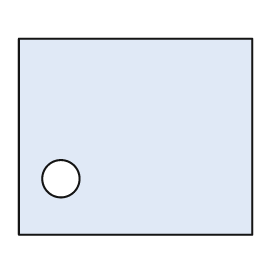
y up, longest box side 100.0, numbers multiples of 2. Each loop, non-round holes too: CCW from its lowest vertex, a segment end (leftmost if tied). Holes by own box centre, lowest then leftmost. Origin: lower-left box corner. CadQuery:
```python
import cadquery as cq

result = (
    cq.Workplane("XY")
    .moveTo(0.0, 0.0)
    .lineTo(100.0, 0.0)
    .lineTo(100.0, 84.0)
    .lineTo(0.0, 84.0)
    .close()
    .moveTo(18.0, 24.0)
    .circle(8.0)
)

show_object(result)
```